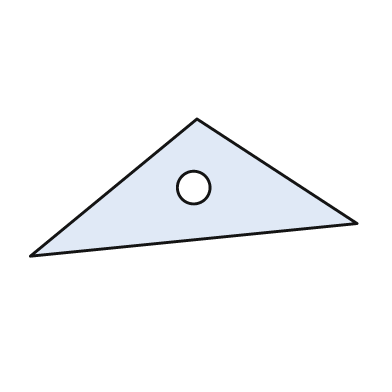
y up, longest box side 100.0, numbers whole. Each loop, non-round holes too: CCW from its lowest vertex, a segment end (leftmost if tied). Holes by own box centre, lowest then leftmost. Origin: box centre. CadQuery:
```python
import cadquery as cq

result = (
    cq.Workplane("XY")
    .moveTo(-50.0, -21.0)
    .lineTo(50.0, -11.0)
    .lineTo(1.0, 21.0)
    .close()
    .moveTo(0.0, 0.0)
    .circle(5.0)
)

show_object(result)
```